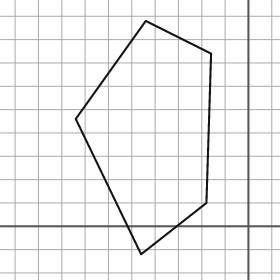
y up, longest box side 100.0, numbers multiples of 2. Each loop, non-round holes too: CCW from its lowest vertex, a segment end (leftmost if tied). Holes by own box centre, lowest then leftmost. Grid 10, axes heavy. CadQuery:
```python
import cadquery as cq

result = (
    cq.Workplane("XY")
    .moveTo(-46.0, -12.0)
    .lineTo(-18.0, 10.0)
    .lineTo(-16.0, 74.0)
    .lineTo(-44.0, 88.0)
    .lineTo(-74.0, 46.0)
    .close()
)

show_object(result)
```